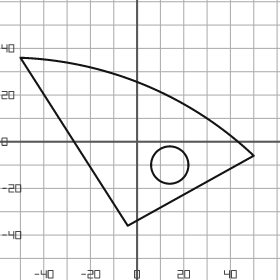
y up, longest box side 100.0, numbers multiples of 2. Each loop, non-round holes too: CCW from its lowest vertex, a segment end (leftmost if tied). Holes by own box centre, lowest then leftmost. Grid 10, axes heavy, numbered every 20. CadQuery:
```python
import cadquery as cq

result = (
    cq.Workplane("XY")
    .moveTo(-4.0, -36.0)
    .lineTo(50.0, -6.0)
    .threePointArc((4.0, 24.0), (-50.0, 36.0))
    .close()
    .moveTo(14.0, -10.0)
    .circle(8.0)
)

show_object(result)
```